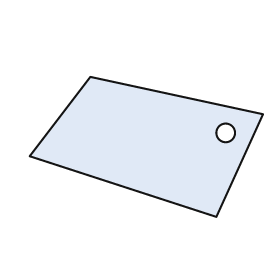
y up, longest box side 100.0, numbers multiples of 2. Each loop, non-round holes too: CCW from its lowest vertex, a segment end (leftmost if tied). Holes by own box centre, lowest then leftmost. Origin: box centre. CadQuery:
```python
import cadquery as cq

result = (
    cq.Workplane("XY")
    .moveTo(30.0, -30.0)
    .lineTo(50.0, 14.0)
    .lineTo(-24.0, 30.0)
    .lineTo(-50.0, -4.0)
    .close()
    .moveTo(34.0, 6.0)
    .circle(4.0)
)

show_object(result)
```